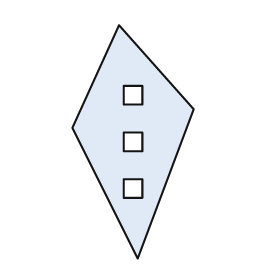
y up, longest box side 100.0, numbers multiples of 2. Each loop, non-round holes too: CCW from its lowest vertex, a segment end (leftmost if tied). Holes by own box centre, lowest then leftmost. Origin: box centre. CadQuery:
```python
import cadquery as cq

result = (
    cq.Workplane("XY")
    .moveTo(2.0, -50.0)
    .lineTo(26.0, 14.0)
    .lineTo(-6.0, 50.0)
    .lineTo(-26.0, 6.0)
    .close()
    .moveTo(-4.0, -24.0)
    .lineTo(4.0, -24.0)
    .lineTo(4.0, -16.0)
    .lineTo(-4.0, -16.0)
    .close()
    .moveTo(-4.0, -4.0)
    .lineTo(4.0, -4.0)
    .lineTo(4.0, 4.0)
    .lineTo(-4.0, 4.0)
    .close()
    .moveTo(-4.0, 16.0)
    .lineTo(4.0, 16.0)
    .lineTo(4.0, 24.0)
    .lineTo(-4.0, 24.0)
    .close()
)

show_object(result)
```